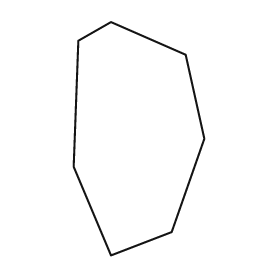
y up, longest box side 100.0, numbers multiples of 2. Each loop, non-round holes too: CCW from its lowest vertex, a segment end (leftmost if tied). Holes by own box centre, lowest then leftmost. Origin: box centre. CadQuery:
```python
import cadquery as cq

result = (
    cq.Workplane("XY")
    .moveTo(-12.0, -50.0)
    .lineTo(14.0, -40.0)
    .lineTo(28.0, 0.0)
    .lineTo(20.0, 36.0)
    .lineTo(-12.0, 50.0)
    .lineTo(-26.0, 42.0)
    .lineTo(-28.0, -12.0)
    .close()
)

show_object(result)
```